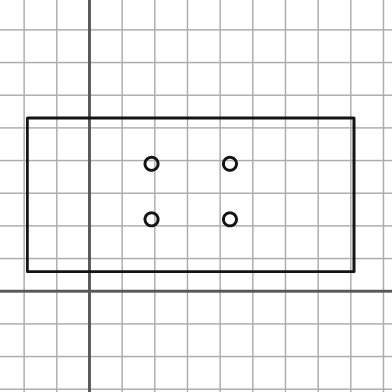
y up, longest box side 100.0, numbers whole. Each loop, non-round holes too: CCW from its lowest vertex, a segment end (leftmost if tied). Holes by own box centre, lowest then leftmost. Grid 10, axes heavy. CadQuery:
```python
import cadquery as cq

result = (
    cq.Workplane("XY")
    .moveTo(-19.0, 6.0)
    .lineTo(81.0, 6.0)
    .lineTo(81.0, 53.0)
    .lineTo(-19.0, 53.0)
    .close()
    .moveTo(19.0, 22.0)
    .circle(2.0)
    .moveTo(43.0, 22.0)
    .circle(2.0)
    .moveTo(19.0, 39.0)
    .circle(2.0)
    .moveTo(43.0, 39.0)
    .circle(2.0)
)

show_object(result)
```